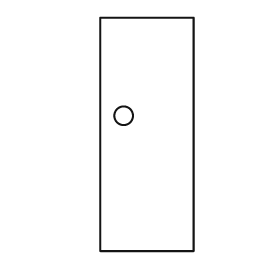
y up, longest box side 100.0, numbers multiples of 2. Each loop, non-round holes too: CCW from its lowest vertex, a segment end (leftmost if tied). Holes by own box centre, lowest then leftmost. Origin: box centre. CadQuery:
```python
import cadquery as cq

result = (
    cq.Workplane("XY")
    .moveTo(-20.0, -50.0)
    .lineTo(20.0, -50.0)
    .lineTo(20.0, 50.0)
    .lineTo(-20.0, 50.0)
    .close()
    .moveTo(-10.0, 8.0)
    .circle(4.0)
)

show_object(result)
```